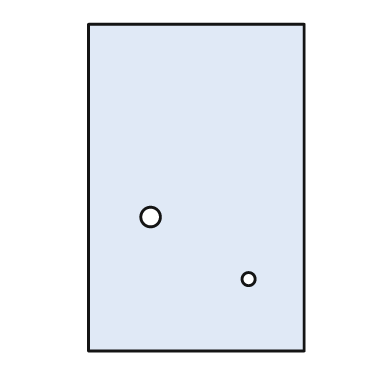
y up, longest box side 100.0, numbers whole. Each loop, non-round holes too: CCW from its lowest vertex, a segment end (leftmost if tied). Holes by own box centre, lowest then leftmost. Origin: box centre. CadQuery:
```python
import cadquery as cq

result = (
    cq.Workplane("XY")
    .moveTo(-33.0, -50.0)
    .lineTo(33.0, -50.0)
    .lineTo(33.0, 50.0)
    .lineTo(-33.0, 50.0)
    .close()
    .moveTo(16.0, -28.0)
    .circle(2.0)
    .moveTo(-14.0, -9.0)
    .circle(3.0)
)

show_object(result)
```